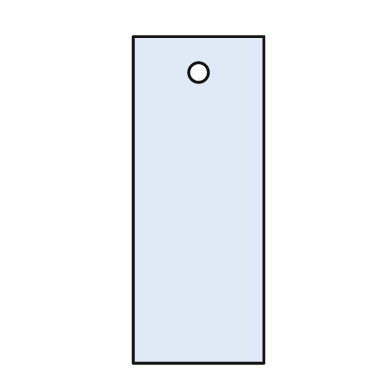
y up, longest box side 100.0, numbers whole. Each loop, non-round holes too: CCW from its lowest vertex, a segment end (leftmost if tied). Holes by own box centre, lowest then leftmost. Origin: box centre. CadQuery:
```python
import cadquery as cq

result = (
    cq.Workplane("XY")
    .moveTo(-20.0, -50.0)
    .lineTo(20.0, -50.0)
    .lineTo(20.0, 50.0)
    .lineTo(-20.0, 50.0)
    .close()
    .moveTo(0.0, 39.0)
    .circle(3.0)
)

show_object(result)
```